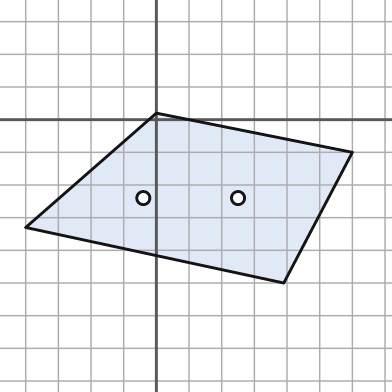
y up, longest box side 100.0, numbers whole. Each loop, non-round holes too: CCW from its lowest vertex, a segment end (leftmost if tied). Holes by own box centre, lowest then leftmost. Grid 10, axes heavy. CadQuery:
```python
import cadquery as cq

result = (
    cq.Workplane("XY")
    .moveTo(39.0, -50.0)
    .lineTo(60.0, -10.0)
    .lineTo(0.0, 2.0)
    .lineTo(-40.0, -33.0)
    .close()
    .moveTo(-4.0, -24.0)
    .circle(2.0)
    .moveTo(25.0, -24.0)
    .circle(2.0)
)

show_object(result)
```